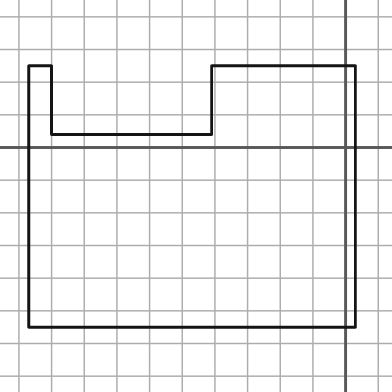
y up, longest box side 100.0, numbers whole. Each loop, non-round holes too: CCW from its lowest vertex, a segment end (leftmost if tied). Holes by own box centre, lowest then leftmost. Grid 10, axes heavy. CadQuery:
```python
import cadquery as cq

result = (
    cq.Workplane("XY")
    .moveTo(-97.0, -55.0)
    .lineTo(3.0, -55.0)
    .lineTo(3.0, 25.0)
    .lineTo(-41.0, 25.0)
    .lineTo(-41.0, 4.0)
    .lineTo(-90.0, 4.0)
    .lineTo(-90.0, 25.0)
    .lineTo(-97.0, 25.0)
    .close()
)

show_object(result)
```